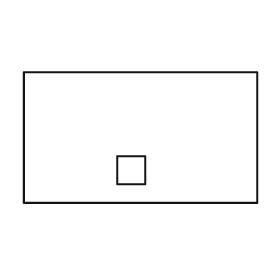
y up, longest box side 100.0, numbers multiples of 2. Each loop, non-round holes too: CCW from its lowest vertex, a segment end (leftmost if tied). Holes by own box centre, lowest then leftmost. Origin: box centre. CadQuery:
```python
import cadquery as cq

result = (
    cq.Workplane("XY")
    .moveTo(-50.0, -28.0)
    .lineTo(50.0, -28.0)
    .lineTo(50.0, 28.0)
    .lineTo(-50.0, 28.0)
    .close()
    .moveTo(-10.0, -20.0)
    .lineTo(2.0, -20.0)
    .lineTo(2.0, -8.0)
    .lineTo(-10.0, -8.0)
    .close()
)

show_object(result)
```